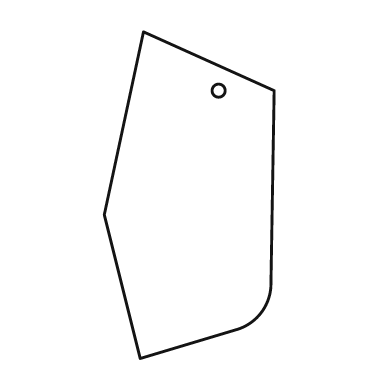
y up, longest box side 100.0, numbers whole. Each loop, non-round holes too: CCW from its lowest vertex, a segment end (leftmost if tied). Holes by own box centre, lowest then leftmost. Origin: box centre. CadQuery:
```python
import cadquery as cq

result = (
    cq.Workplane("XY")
    .moveTo(-15.0, -50.0)
    .lineTo(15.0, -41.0)
    .threePointArc((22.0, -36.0), (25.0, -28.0))
    .lineTo(26.0, 32.0)
    .lineTo(-14.0, 50.0)
    .lineTo(-26.0, -6.0)
    .close()
    .moveTo(9.0, 32.0)
    .circle(2.0)
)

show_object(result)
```